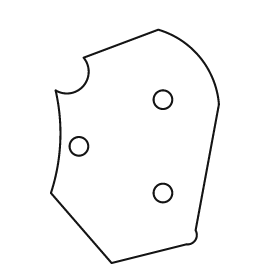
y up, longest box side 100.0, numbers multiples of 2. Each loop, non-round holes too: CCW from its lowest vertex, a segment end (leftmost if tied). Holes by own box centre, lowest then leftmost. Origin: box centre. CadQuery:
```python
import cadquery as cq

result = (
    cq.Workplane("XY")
    .moveTo(-10.0, -50.0)
    .lineTo(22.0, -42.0)
    .threePointArc((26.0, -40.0), (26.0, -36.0))
    .lineTo(36.0, 18.0)
    .threePointArc((28.0, 38.0), (10.0, 50.0))
    .lineTo(-22.0, 38.0)
    .threePointArc((-22.0, 26.0), (-34.0, 24.0))
    .threePointArc((-32.0, 2.0), (-36.0, -20.0))
    .close()
    .moveTo(12.0, -20.0)
    .circle(4.0)
    .moveTo(-24.0, 0.0)
    .circle(4.0)
    .moveTo(12.0, 20.0)
    .circle(4.0)
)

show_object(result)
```